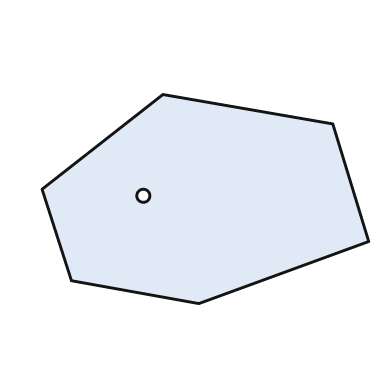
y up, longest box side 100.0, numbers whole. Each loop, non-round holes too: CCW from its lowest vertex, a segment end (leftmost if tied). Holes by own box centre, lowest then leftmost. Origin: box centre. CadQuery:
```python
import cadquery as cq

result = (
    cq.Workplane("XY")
    .moveTo(-2.0, -32.0)
    .lineTo(50.0, -13.0)
    .lineTo(39.0, 23.0)
    .lineTo(-13.0, 32.0)
    .lineTo(-50.0, 3.0)
    .lineTo(-41.0, -25.0)
    .close()
    .moveTo(-19.0, 1.0)
    .circle(2.0)
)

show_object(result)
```